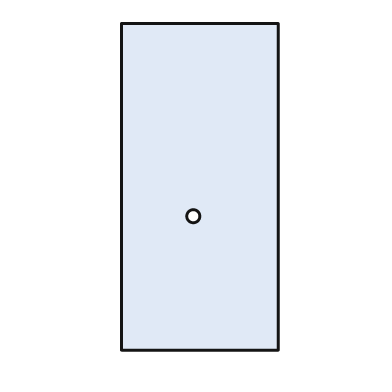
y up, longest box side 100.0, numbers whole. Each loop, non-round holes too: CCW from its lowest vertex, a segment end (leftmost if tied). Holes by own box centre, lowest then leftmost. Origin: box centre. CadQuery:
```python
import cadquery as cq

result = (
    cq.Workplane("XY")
    .moveTo(-24.0, -50.0)
    .lineTo(24.0, -50.0)
    .lineTo(24.0, 50.0)
    .lineTo(-24.0, 50.0)
    .close()
    .moveTo(-2.0, -9.0)
    .circle(2.0)
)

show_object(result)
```